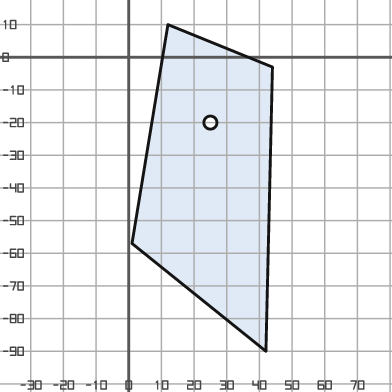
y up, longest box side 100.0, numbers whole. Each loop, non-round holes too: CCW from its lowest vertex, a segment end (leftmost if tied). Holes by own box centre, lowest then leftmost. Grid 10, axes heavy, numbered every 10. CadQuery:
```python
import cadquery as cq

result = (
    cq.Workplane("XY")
    .moveTo(42.0, -90.0)
    .lineTo(44.0, -3.0)
    .lineTo(12.0, 10.0)
    .lineTo(1.0, -57.0)
    .close()
    .moveTo(25.0, -20.0)
    .circle(2.0)
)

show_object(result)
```